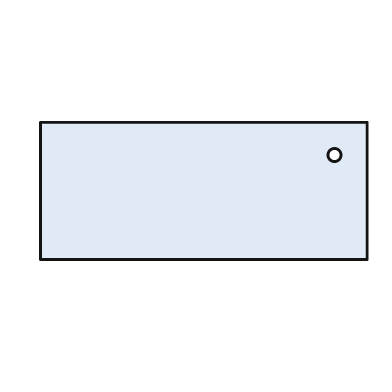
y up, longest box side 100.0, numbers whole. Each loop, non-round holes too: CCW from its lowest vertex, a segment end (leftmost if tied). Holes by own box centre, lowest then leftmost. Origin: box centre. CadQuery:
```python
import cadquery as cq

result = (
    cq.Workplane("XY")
    .moveTo(-50.0, -21.0)
    .lineTo(50.0, -21.0)
    .lineTo(50.0, 21.0)
    .lineTo(-50.0, 21.0)
    .close()
    .moveTo(40.0, 11.0)
    .circle(2.0)
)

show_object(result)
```